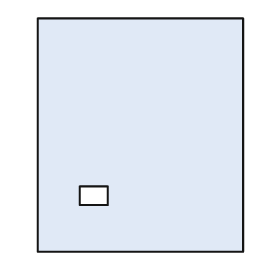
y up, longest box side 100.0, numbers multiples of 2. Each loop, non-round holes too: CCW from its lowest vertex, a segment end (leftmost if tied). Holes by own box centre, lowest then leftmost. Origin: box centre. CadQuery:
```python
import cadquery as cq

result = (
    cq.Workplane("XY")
    .moveTo(-44.0, -50.0)
    .lineTo(44.0, -50.0)
    .lineTo(44.0, 50.0)
    .lineTo(-44.0, 50.0)
    .close()
    .moveTo(-26.0, -30.0)
    .lineTo(-14.0, -30.0)
    .lineTo(-14.0, -22.0)
    .lineTo(-26.0, -22.0)
    .close()
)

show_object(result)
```